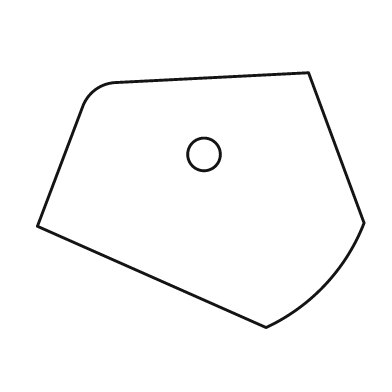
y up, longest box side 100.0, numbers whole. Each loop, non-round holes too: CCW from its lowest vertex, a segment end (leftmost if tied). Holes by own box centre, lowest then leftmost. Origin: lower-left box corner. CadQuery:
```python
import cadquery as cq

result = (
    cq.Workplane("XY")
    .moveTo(70.0, 0.0)
    .threePointArc((88.0, 13.0), (100.0, 32.0))
    .lineTo(83.0, 78.0)
    .lineTo(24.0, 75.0)
    .threePointArc((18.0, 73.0), (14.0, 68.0))
    .lineTo(0.0, 31.0)
    .close()
    .moveTo(51.0, 53.0)
    .circle(5.0)
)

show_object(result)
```